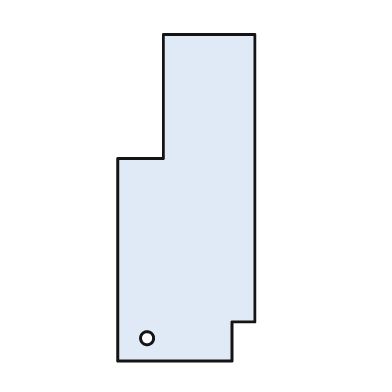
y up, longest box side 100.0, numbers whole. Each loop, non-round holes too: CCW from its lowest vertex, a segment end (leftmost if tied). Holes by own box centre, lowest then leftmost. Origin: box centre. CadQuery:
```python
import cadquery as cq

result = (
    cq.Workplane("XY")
    .moveTo(-21.0, -50.0)
    .lineTo(14.0, -50.0)
    .lineTo(14.0, -38.0)
    .lineTo(21.0, -38.0)
    .lineTo(21.0, 50.0)
    .lineTo(-7.0, 50.0)
    .lineTo(-7.0, 12.0)
    .lineTo(-21.0, 12.0)
    .close()
    .moveTo(-12.0, -43.0)
    .circle(2.0)
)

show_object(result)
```